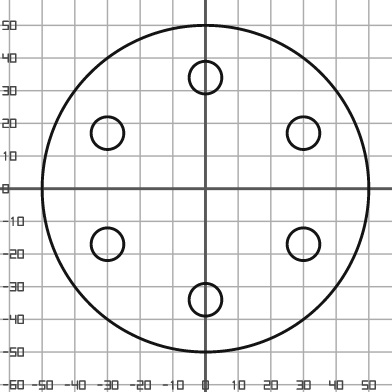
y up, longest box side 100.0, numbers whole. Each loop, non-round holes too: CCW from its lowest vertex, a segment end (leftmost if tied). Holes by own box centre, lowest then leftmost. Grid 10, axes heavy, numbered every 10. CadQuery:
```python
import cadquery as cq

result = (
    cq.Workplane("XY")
    .moveTo(0.0, 0.0)
    .circle(50.0)
    .moveTo(0.0, -34.0)
    .circle(5.0)
    .moveTo(-30.0, -17.0)
    .circle(5.0)
    .moveTo(30.0, -17.0)
    .circle(5.0)
    .moveTo(-30.0, 17.0)
    .circle(5.0)
    .moveTo(30.0, 17.0)
    .circle(5.0)
    .moveTo(0.0, 34.0)
    .circle(5.0)
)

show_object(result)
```